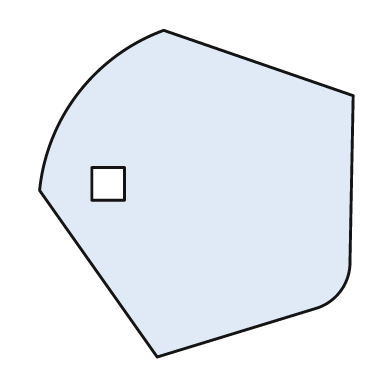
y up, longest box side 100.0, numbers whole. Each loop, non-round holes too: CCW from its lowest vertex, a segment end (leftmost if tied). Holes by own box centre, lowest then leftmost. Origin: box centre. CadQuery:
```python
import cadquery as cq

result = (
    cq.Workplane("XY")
    .moveTo(-12.0, -50.0)
    .lineTo(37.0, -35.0)
    .threePointArc((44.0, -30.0), (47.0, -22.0))
    .lineTo(48.0, 30.0)
    .lineTo(-10.0, 50.0)
    .threePointArc((-36.0, 31.0), (-48.0, 1.0))
    .close()
    .moveTo(-32.0, -2.0)
    .lineTo(-22.0, -2.0)
    .lineTo(-22.0, 8.0)
    .lineTo(-32.0, 8.0)
    .close()
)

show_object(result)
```